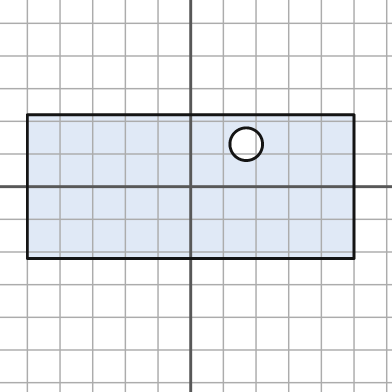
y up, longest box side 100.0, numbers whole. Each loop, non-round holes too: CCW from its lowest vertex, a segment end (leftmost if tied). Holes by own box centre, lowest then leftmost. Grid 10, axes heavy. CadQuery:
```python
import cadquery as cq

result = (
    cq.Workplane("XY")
    .moveTo(-50.0, -22.0)
    .lineTo(50.0, -22.0)
    .lineTo(50.0, 22.0)
    .lineTo(-50.0, 22.0)
    .close()
    .moveTo(17.0, 13.0)
    .circle(5.0)
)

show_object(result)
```